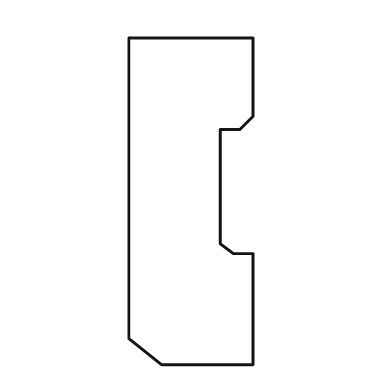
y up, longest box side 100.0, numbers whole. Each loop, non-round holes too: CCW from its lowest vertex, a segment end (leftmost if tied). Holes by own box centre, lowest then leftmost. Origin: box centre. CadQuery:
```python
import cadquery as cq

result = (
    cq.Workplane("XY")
    .moveTo(-9.0, -50.0)
    .lineTo(19.0, -50.0)
    .lineTo(19.0, -16.0)
    .lineTo(13.0, -16.0)
    .lineTo(9.0, -13.0)
    .lineTo(9.0, 22.0)
    .lineTo(15.0, 22.0)
    .lineTo(19.0, 26.0)
    .lineTo(19.0, 50.0)
    .lineTo(-19.0, 50.0)
    .lineTo(-19.0, -42.0)
    .close()
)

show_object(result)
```